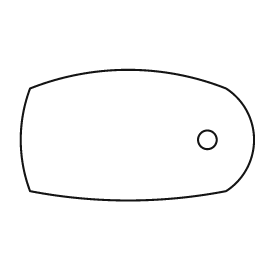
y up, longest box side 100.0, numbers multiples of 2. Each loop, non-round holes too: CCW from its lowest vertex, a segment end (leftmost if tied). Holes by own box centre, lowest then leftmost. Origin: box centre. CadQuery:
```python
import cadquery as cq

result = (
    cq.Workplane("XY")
    .moveTo(-46.0, -24.0)
    .threePointArc((-4.0, -28.0), (38.0, -24.0))
    .threePointArc((50.0, -2.0), (38.0, 20.0))
    .threePointArc((-4.0, 28.0), (-46.0, 20.0))
    .threePointArc((-50.0, -2.0), (-46.0, -24.0))
    .close()
    .moveTo(30.0, -2.0)
    .circle(4.0)
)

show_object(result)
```